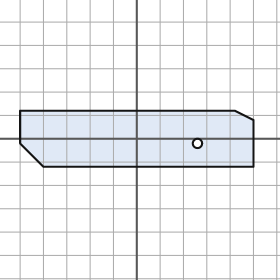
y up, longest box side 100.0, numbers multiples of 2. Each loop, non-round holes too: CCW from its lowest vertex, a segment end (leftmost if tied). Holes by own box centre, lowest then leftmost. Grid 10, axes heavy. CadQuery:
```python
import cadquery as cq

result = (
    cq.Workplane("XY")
    .moveTo(-40.0, -12.0)
    .lineTo(50.0, -12.0)
    .lineTo(50.0, 8.0)
    .lineTo(42.0, 12.0)
    .lineTo(-50.0, 12.0)
    .lineTo(-50.0, -2.0)
    .close()
    .moveTo(26.0, -2.0)
    .circle(2.0)
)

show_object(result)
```